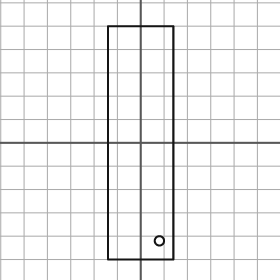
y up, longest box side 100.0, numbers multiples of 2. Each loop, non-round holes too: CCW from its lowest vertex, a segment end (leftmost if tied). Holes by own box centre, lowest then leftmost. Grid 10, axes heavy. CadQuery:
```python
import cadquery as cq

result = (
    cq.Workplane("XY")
    .moveTo(-14.0, -50.0)
    .lineTo(14.0, -50.0)
    .lineTo(14.0, 50.0)
    .lineTo(-14.0, 50.0)
    .close()
    .moveTo(8.0, -42.0)
    .circle(2.0)
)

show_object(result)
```